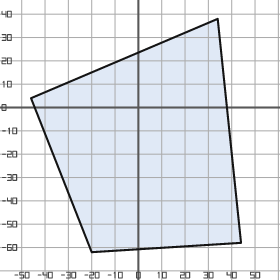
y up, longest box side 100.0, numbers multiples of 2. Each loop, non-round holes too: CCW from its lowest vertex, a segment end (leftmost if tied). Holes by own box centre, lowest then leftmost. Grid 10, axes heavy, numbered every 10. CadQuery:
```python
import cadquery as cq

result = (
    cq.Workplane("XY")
    .moveTo(-20.0, -62.0)
    .lineTo(44.0, -58.0)
    .lineTo(34.0, 38.0)
    .lineTo(-46.0, 4.0)
    .close()
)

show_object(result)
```